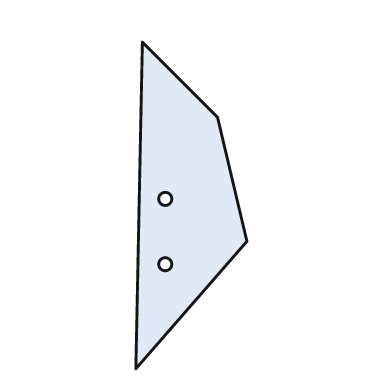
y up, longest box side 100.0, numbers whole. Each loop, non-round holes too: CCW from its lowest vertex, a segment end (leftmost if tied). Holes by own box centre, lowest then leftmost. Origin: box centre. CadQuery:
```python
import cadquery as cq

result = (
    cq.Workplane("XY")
    .moveTo(-17.0, -50.0)
    .lineTo(17.0, -11.0)
    .lineTo(8.0, 27.0)
    .lineTo(-15.0, 50.0)
    .close()
    .moveTo(-8.0, -18.0)
    .circle(2.0)
    .moveTo(-8.0, 2.0)
    .circle(2.0)
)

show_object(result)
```